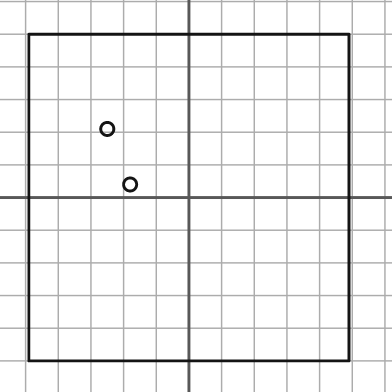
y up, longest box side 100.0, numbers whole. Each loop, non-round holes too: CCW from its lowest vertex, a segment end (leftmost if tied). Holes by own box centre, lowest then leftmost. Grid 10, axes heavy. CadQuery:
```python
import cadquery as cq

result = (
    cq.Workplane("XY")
    .moveTo(-49.0, -50.0)
    .lineTo(49.0, -50.0)
    .lineTo(49.0, 50.0)
    .lineTo(-49.0, 50.0)
    .close()
    .moveTo(-18.0, 4.0)
    .circle(2.0)
    .moveTo(-25.0, 21.0)
    .circle(2.0)
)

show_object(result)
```